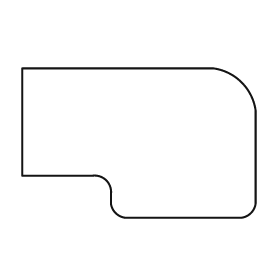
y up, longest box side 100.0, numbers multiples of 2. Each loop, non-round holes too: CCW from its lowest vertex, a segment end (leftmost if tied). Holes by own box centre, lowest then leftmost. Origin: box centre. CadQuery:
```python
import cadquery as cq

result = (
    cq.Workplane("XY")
    .moveTo(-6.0, -32.0)
    .lineTo(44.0, -32.0)
    .threePointArc((48.0, -30.0), (50.0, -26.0))
    .lineTo(50.0, 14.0)
    .threePointArc((44.0, 26.0), (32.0, 32.0))
    .lineTo(-50.0, 32.0)
    .lineTo(-50.0, -14.0)
    .lineTo(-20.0, -14.0)
    .threePointArc((-14.0, -16.0), (-12.0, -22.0))
    .lineTo(-12.0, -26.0)
    .threePointArc((-10.0, -30.0), (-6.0, -32.0))
    .close()
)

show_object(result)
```